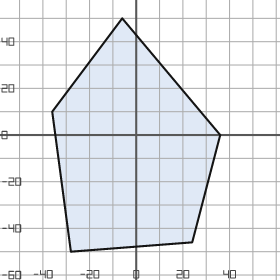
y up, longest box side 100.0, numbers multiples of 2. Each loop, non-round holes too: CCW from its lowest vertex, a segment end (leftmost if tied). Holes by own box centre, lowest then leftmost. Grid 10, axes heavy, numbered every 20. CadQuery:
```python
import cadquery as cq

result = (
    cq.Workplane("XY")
    .moveTo(-28.0, -50.0)
    .lineTo(24.0, -46.0)
    .lineTo(36.0, 0.0)
    .lineTo(-6.0, 50.0)
    .lineTo(-36.0, 10.0)
    .close()
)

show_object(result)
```